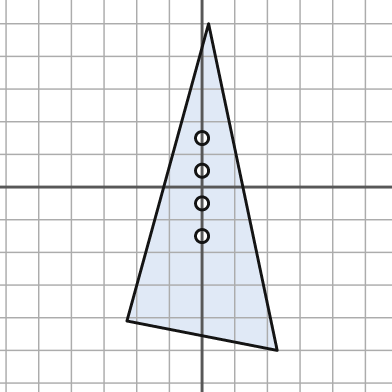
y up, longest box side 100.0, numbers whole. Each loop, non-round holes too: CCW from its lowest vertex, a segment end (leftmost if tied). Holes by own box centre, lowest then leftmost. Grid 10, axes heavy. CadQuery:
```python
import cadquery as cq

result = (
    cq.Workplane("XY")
    .moveTo(23.0, -50.0)
    .lineTo(2.0, 50.0)
    .lineTo(-23.0, -41.0)
    .close()
    .moveTo(0.0, -15.0)
    .circle(2.0)
    .moveTo(0.0, -5.0)
    .circle(2.0)
    .moveTo(0.0, 5.0)
    .circle(2.0)
    .moveTo(0.0, 15.0)
    .circle(2.0)
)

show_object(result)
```